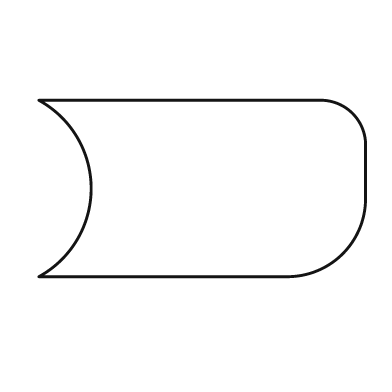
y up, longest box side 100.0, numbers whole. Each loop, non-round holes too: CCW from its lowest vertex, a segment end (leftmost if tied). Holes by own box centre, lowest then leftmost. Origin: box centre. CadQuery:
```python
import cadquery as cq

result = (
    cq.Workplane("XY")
    .moveTo(-50.0, -27.0)
    .lineTo(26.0, -27.0)
    .threePointArc((43.0, -20.0), (50.0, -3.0))
    .lineTo(50.0, 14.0)
    .threePointArc((46.0, 23.0), (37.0, 27.0))
    .lineTo(-50.0, 27.0)
    .threePointArc((-34.0, 0.0), (-50.0, -27.0))
    .close()
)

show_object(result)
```